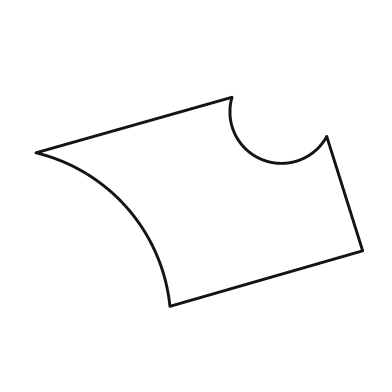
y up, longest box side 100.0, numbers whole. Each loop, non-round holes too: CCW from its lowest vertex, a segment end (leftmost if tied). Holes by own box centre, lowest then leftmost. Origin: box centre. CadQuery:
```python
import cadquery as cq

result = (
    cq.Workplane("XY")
    .moveTo(-9.0, -32.0)
    .lineTo(50.0, -15.0)
    .lineTo(39.0, 20.0)
    .threePointArc((19.0, 13.0), (10.0, 32.0))
    .lineTo(-50.0, 15.0)
    .threePointArc((-22.0, -2.0), (-9.0, -32.0))
    .close()
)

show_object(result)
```